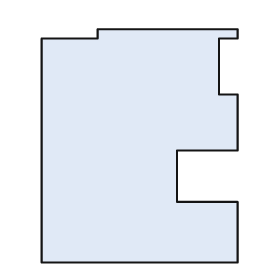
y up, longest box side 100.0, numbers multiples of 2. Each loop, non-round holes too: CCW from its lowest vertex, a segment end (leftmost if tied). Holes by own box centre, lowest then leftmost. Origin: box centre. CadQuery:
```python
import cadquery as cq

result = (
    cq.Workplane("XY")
    .moveTo(-42.0, -50.0)
    .lineTo(42.0, -50.0)
    .lineTo(42.0, -24.0)
    .lineTo(16.0, -24.0)
    .lineTo(16.0, -2.0)
    .lineTo(42.0, -2.0)
    .lineTo(42.0, 22.0)
    .lineTo(34.0, 22.0)
    .lineTo(34.0, 46.0)
    .lineTo(42.0, 46.0)
    .lineTo(42.0, 50.0)
    .lineTo(-18.0, 50.0)
    .lineTo(-18.0, 46.0)
    .lineTo(-42.0, 46.0)
    .close()
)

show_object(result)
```